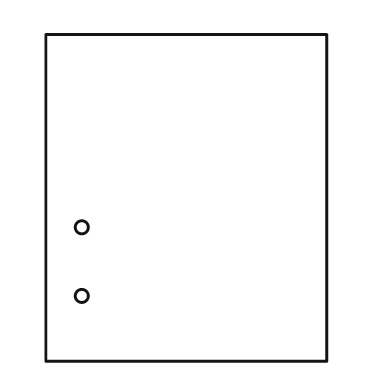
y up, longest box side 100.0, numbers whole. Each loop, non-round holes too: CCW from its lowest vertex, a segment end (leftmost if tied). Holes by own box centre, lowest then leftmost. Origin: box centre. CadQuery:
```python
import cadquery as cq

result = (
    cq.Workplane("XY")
    .moveTo(-43.0, -50.0)
    .lineTo(43.0, -50.0)
    .lineTo(43.0, 50.0)
    .lineTo(-43.0, 50.0)
    .close()
    .moveTo(-32.0, -30.0)
    .circle(2.0)
    .moveTo(-32.0, -9.0)
    .circle(2.0)
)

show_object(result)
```